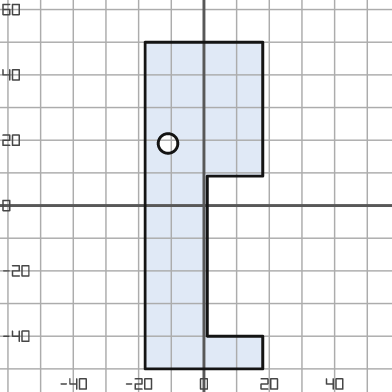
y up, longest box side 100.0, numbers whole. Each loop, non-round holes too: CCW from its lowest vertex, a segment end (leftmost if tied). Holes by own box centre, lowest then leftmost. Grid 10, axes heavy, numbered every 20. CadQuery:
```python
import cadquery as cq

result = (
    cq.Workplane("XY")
    .moveTo(-18.0, -50.0)
    .lineTo(18.0, -50.0)
    .lineTo(18.0, -40.0)
    .lineTo(1.0, -40.0)
    .lineTo(1.0, 9.0)
    .lineTo(18.0, 9.0)
    .lineTo(18.0, 50.0)
    .lineTo(-18.0, 50.0)
    .close()
    .moveTo(-11.0, 19.0)
    .circle(3.0)
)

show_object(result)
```